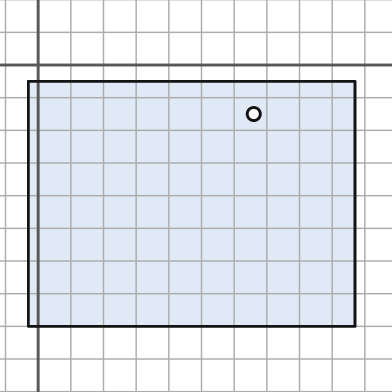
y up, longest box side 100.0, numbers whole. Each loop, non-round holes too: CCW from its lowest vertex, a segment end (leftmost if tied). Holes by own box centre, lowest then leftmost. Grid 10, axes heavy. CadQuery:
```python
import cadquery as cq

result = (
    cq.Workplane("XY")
    .moveTo(-3.0, -80.0)
    .lineTo(97.0, -80.0)
    .lineTo(97.0, -5.0)
    .lineTo(-3.0, -5.0)
    .close()
    .moveTo(66.0, -15.0)
    .circle(2.0)
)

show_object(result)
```